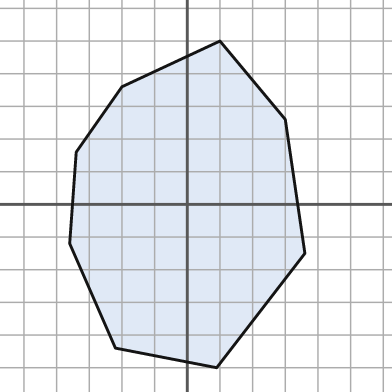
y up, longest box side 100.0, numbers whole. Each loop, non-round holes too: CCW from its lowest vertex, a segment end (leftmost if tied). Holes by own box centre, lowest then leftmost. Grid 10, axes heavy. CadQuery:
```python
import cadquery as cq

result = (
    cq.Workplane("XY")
    .moveTo(9.0, -50.0)
    .lineTo(36.0, -15.0)
    .lineTo(30.0, 26.0)
    .lineTo(10.0, 50.0)
    .lineTo(-20.0, 36.0)
    .lineTo(-34.0, 16.0)
    .lineTo(-36.0, -12.0)
    .lineTo(-22.0, -44.0)
    .close()
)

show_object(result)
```